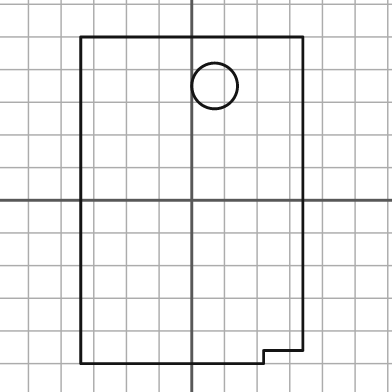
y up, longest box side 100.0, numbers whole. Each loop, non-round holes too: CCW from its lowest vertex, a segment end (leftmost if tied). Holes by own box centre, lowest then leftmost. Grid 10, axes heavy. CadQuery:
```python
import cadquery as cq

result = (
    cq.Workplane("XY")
    .moveTo(-34.0, -50.0)
    .lineTo(22.0, -50.0)
    .lineTo(22.0, -46.0)
    .lineTo(34.0, -46.0)
    .lineTo(34.0, 50.0)
    .lineTo(-34.0, 50.0)
    .close()
    .moveTo(7.0, 35.0)
    .circle(7.0)
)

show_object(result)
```